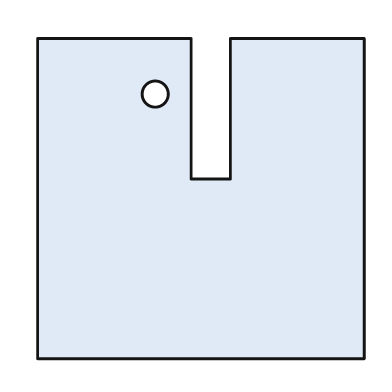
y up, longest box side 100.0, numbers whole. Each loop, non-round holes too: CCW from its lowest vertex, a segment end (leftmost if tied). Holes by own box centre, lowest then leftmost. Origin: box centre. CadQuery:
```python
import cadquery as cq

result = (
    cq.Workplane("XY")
    .moveTo(-50.0, -49.0)
    .lineTo(50.0, -49.0)
    .lineTo(50.0, 49.0)
    .lineTo(9.0, 49.0)
    .lineTo(9.0, 6.0)
    .lineTo(-3.0, 6.0)
    .lineTo(-3.0, 49.0)
    .lineTo(-50.0, 49.0)
    .close()
    .moveTo(-14.0, 32.0)
    .circle(4.0)
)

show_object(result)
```